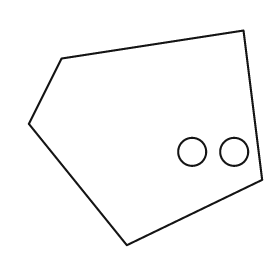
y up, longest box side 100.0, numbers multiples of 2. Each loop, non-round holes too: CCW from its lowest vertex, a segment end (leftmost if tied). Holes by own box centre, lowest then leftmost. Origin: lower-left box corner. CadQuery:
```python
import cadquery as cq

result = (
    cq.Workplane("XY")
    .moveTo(42.0, 0.0)
    .lineTo(100.0, 28.0)
    .lineTo(92.0, 92.0)
    .lineTo(14.0, 80.0)
    .lineTo(0.0, 52.0)
    .close()
    .moveTo(70.0, 40.0)
    .circle(6.0)
    .moveTo(88.0, 40.0)
    .circle(6.0)
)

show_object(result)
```